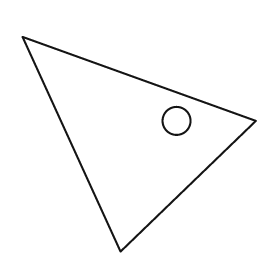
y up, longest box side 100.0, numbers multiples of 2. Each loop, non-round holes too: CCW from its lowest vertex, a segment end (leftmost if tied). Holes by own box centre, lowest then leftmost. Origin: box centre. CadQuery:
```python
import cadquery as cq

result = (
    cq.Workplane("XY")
    .moveTo(-8.0, -46.0)
    .lineTo(50.0, 10.0)
    .lineTo(-50.0, 46.0)
    .close()
    .moveTo(16.0, 10.0)
    .circle(6.0)
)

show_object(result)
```